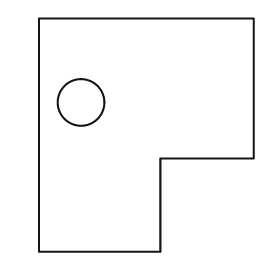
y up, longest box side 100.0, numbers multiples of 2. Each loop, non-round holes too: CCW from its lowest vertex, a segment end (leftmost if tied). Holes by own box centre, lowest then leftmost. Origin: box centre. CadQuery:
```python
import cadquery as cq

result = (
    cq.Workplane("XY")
    .moveTo(-46.0, -50.0)
    .lineTo(6.0, -50.0)
    .lineTo(6.0, -10.0)
    .lineTo(46.0, -10.0)
    .lineTo(46.0, 50.0)
    .lineTo(-46.0, 50.0)
    .close()
    .moveTo(-28.0, 14.0)
    .circle(10.0)
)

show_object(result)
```